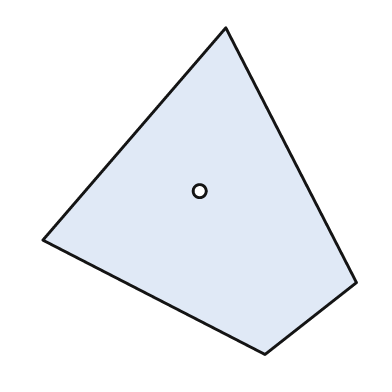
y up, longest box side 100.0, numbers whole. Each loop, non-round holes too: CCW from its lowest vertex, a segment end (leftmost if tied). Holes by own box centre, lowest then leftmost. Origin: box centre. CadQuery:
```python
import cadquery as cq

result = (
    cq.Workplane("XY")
    .moveTo(20.0, -50.0)
    .lineTo(48.0, -28.0)
    .lineTo(8.0, 50.0)
    .lineTo(-48.0, -15.0)
    .close()
    .moveTo(0.0, 0.0)
    .circle(2.0)
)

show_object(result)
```